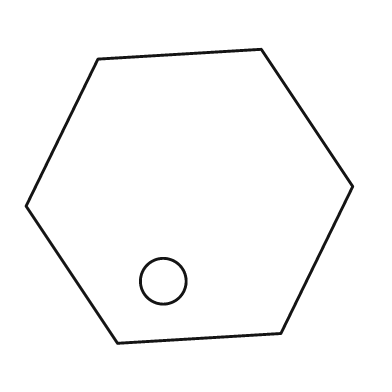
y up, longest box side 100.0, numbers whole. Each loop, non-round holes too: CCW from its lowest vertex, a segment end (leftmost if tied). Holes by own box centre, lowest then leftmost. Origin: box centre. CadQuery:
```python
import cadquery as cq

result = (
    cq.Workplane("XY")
    .moveTo(-22.0, -45.0)
    .lineTo(28.0, -42.0)
    .lineTo(50.0, 3.0)
    .lineTo(22.0, 45.0)
    .lineTo(-28.0, 42.0)
    .lineTo(-50.0, -3.0)
    .close()
    .moveTo(-8.0, -26.0)
    .circle(7.0)
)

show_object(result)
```